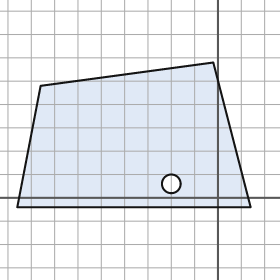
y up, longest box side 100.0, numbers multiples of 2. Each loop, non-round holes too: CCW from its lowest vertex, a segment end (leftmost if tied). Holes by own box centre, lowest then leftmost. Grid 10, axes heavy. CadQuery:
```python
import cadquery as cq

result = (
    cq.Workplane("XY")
    .moveTo(-86.0, -4.0)
    .lineTo(14.0, -4.0)
    .lineTo(-2.0, 58.0)
    .lineTo(-76.0, 48.0)
    .close()
    .moveTo(-20.0, 6.0)
    .circle(4.0)
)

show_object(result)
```